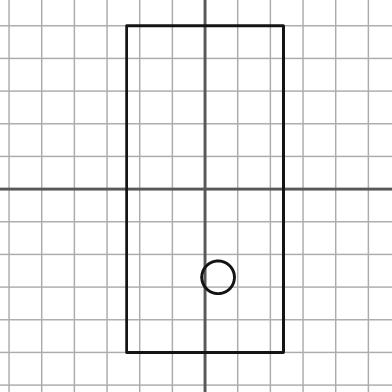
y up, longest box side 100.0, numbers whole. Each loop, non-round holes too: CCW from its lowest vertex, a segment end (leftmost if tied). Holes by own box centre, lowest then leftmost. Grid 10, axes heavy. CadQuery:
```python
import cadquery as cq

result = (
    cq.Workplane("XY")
    .moveTo(-24.0, -50.0)
    .lineTo(24.0, -50.0)
    .lineTo(24.0, 50.0)
    .lineTo(-24.0, 50.0)
    .close()
    .moveTo(4.0, -27.0)
    .circle(5.0)
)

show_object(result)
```